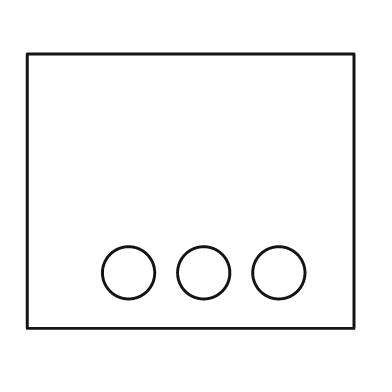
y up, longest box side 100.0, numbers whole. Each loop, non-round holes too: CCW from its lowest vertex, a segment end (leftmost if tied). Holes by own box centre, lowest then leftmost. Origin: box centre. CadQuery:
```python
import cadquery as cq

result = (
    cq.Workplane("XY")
    .moveTo(-50.0, -42.0)
    .lineTo(50.0, -42.0)
    .lineTo(50.0, 42.0)
    .lineTo(-50.0, 42.0)
    .close()
    .moveTo(-19.0, -25.0)
    .circle(8.0)
    .moveTo(4.0, -25.0)
    .circle(8.0)
    .moveTo(27.0, -25.0)
    .circle(8.0)
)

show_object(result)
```